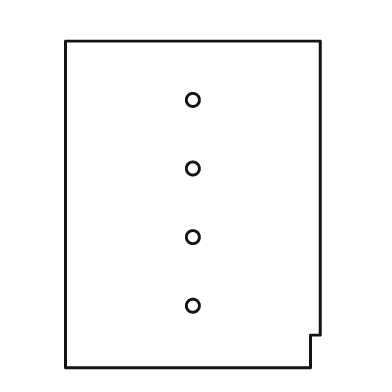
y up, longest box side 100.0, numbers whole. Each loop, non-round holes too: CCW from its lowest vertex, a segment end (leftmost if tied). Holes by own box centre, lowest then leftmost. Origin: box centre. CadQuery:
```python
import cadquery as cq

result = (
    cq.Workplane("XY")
    .moveTo(-39.0, -50.0)
    .lineTo(36.0, -50.0)
    .lineTo(36.0, -40.0)
    .lineTo(39.0, -40.0)
    .lineTo(39.0, 50.0)
    .lineTo(-39.0, 50.0)
    .close()
    .moveTo(0.0, -31.0)
    .circle(2.0)
    .moveTo(0.0, -10.0)
    .circle(2.0)
    .moveTo(0.0, 11.0)
    .circle(2.0)
    .moveTo(0.0, 32.0)
    .circle(2.0)
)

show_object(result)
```